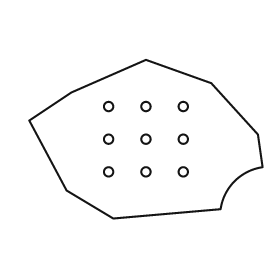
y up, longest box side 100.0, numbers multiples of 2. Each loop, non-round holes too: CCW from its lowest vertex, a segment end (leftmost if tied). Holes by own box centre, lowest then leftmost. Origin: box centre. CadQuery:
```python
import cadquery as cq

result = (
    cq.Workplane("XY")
    .moveTo(-14.0, -34.0)
    .lineTo(32.0, -30.0)
    .threePointArc((38.0, -18.0), (50.0, -12.0))
    .lineTo(48.0, 2.0)
    .lineTo(28.0, 24.0)
    .lineTo(0.0, 34.0)
    .lineTo(-32.0, 20.0)
    .lineTo(-50.0, 8.0)
    .lineTo(-34.0, -22.0)
    .close()
    .moveTo(-16.0, -14.0)
    .circle(2.0)
    .moveTo(0.0, -14.0)
    .circle(2.0)
    .moveTo(16.0, -14.0)
    .circle(2.0)
    .moveTo(-16.0, 0.0)
    .circle(2.0)
    .moveTo(0.0, 0.0)
    .circle(2.0)
    .moveTo(16.0, 0.0)
    .circle(2.0)
    .moveTo(-16.0, 14.0)
    .circle(2.0)
    .moveTo(0.0, 14.0)
    .circle(2.0)
    .moveTo(16.0, 14.0)
    .circle(2.0)
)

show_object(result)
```